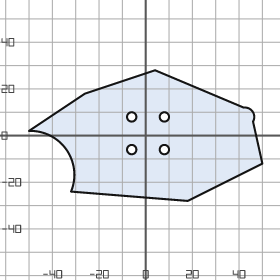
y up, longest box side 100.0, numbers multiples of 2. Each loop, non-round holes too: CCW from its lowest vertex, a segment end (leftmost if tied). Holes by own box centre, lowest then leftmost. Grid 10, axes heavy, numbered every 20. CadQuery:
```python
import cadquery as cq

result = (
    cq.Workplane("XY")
    .moveTo(18.0, -28.0)
    .lineTo(50.0, -12.0)
    .lineTo(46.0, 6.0)
    .threePointArc((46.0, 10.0), (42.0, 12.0))
    .lineTo(4.0, 28.0)
    .lineTo(-26.0, 18.0)
    .lineTo(-50.0, 2.0)
    .threePointArc((-34.0, -6.0), (-32.0, -24.0))
    .close()
    .moveTo(-6.0, -6.0)
    .circle(2.0)
    .moveTo(8.0, -6.0)
    .circle(2.0)
    .moveTo(-6.0, 8.0)
    .circle(2.0)
    .moveTo(8.0, 8.0)
    .circle(2.0)
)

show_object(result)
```